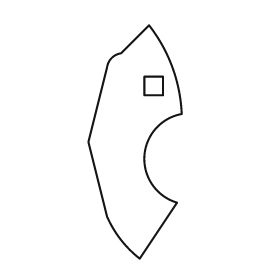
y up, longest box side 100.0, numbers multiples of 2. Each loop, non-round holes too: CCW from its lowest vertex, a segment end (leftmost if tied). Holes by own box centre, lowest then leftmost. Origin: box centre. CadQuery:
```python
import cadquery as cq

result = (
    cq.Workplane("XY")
    .moveTo(2.0, -50.0)
    .lineTo(18.0, -26.0)
    .threePointArc((4.0, -6.0), (20.0, 12.0))
    .threePointArc((16.0, 32.0), (6.0, 50.0))
    .lineTo(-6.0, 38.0)
    .threePointArc((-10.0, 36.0), (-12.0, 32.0))
    .lineTo(-20.0, 0.0)
    .lineTo(-12.0, -32.0)
    .threePointArc((-6.0, -42.0), (2.0, -50.0))
    .close()
    .moveTo(4.0, 20.0)
    .lineTo(12.0, 20.0)
    .lineTo(12.0, 28.0)
    .lineTo(4.0, 28.0)
    .close()
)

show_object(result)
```